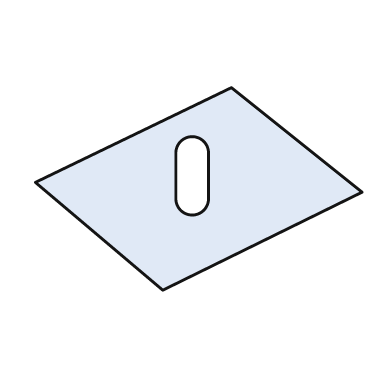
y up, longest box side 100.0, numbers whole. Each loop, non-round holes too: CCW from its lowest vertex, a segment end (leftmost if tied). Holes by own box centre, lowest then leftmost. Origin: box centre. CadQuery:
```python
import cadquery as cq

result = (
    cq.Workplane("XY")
    .moveTo(-11.0, -31.0)
    .lineTo(50.0, -1.0)
    .lineTo(10.0, 31.0)
    .lineTo(-50.0, 2.0)
    .close()
    .moveTo(-7.0, -3.0)
    .threePointArc((-2.0, -8.0), (3.0, -3.0))
    .lineTo(3.0, 11.0)
    .threePointArc((-2.0, 16.0), (-7.0, 11.0))
    .close()
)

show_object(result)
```